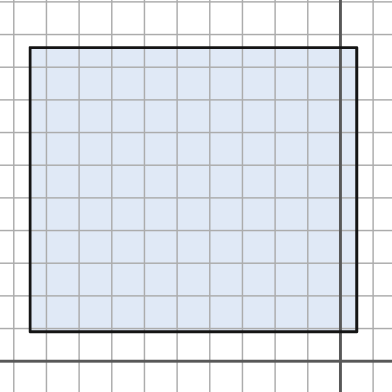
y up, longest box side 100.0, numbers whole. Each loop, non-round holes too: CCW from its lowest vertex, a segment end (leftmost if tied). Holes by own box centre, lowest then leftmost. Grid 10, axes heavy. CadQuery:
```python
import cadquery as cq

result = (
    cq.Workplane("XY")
    .moveTo(-95.0, 9.0)
    .lineTo(5.0, 9.0)
    .lineTo(5.0, 96.0)
    .lineTo(-95.0, 96.0)
    .close()
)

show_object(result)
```